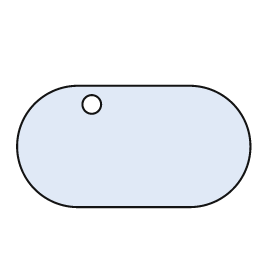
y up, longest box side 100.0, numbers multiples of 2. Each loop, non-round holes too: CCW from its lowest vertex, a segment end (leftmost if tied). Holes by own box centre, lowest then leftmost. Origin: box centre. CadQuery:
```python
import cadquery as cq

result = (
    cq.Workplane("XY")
    .moveTo(-24.0, -26.0)
    .lineTo(24.0, -26.0)
    .threePointArc((50.0, 0.0), (24.0, 26.0))
    .lineTo(-24.0, 26.0)
    .threePointArc((-50.0, 0.0), (-24.0, -26.0))
    .close()
    .moveTo(-18.0, 18.0)
    .circle(4.0)
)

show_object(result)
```